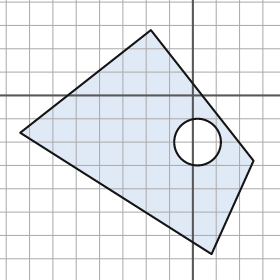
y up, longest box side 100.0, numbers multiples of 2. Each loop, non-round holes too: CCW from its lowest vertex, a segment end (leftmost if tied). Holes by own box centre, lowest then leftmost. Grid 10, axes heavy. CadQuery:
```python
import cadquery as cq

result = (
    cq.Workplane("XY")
    .moveTo(8.0, -68.0)
    .lineTo(26.0, -28.0)
    .lineTo(-18.0, 28.0)
    .lineTo(-74.0, -16.0)
    .close()
    .moveTo(2.0, -20.0)
    .circle(10.0)
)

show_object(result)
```